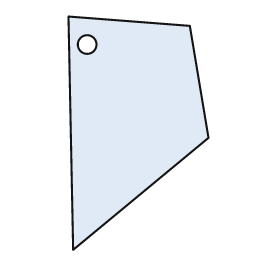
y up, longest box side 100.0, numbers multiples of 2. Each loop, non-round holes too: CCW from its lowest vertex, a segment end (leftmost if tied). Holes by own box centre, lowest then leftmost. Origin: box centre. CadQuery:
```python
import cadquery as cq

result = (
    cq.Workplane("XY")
    .moveTo(-28.0, -50.0)
    .lineTo(30.0, -2.0)
    .lineTo(22.0, 46.0)
    .lineTo(-30.0, 50.0)
    .close()
    .moveTo(-22.0, 38.0)
    .circle(4.0)
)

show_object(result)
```